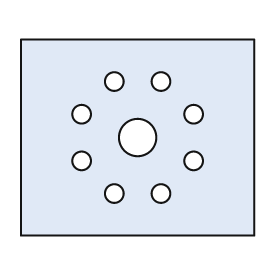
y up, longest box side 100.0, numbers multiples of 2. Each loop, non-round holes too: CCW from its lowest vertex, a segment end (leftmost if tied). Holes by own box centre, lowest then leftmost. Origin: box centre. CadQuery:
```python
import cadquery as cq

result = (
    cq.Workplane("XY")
    .moveTo(-50.0, -42.0)
    .lineTo(50.0, -42.0)
    .lineTo(50.0, 42.0)
    .lineTo(-50.0, 42.0)
    .close()
    .moveTo(-10.0, -24.0)
    .circle(4.0)
    .moveTo(10.0, -24.0)
    .circle(4.0)
    .moveTo(-24.0, -10.0)
    .circle(4.0)
    .moveTo(24.0, -10.0)
    .circle(4.0)
    .moveTo(0.0, 0.0)
    .circle(8.0)
    .moveTo(-24.0, 10.0)
    .circle(4.0)
    .moveTo(24.0, 10.0)
    .circle(4.0)
    .moveTo(-10.0, 24.0)
    .circle(4.0)
    .moveTo(10.0, 24.0)
    .circle(4.0)
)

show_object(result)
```